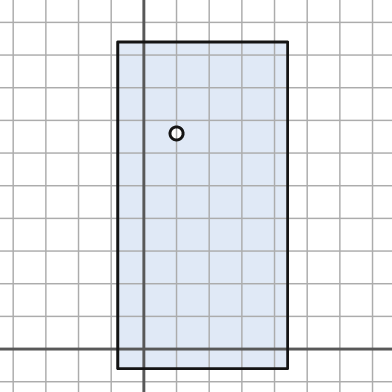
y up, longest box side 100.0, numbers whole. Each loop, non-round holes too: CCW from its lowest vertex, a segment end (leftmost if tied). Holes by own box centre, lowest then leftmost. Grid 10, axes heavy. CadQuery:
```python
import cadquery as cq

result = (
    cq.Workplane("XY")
    .moveTo(-8.0, -6.0)
    .lineTo(44.0, -6.0)
    .lineTo(44.0, 94.0)
    .lineTo(-8.0, 94.0)
    .close()
    .moveTo(10.0, 66.0)
    .circle(2.0)
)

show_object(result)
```